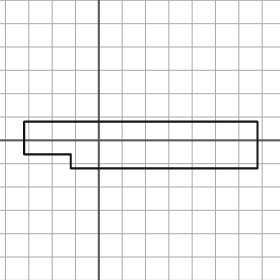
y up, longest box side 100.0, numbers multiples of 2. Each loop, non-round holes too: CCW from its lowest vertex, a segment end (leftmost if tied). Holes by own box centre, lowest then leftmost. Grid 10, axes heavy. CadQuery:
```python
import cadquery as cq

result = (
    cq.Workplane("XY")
    .moveTo(-12.0, -12.0)
    .lineTo(68.0, -12.0)
    .lineTo(68.0, 8.0)
    .lineTo(-32.0, 8.0)
    .lineTo(-32.0, -6.0)
    .lineTo(-12.0, -6.0)
    .close()
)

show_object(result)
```